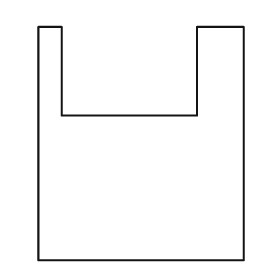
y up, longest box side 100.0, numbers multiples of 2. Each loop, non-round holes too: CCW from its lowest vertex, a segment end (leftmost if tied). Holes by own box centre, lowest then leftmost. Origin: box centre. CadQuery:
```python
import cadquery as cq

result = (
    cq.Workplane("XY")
    .moveTo(-44.0, -50.0)
    .lineTo(44.0, -50.0)
    .lineTo(44.0, 50.0)
    .lineTo(24.0, 50.0)
    .lineTo(24.0, 12.0)
    .lineTo(-34.0, 12.0)
    .lineTo(-34.0, 50.0)
    .lineTo(-44.0, 50.0)
    .close()
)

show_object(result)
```